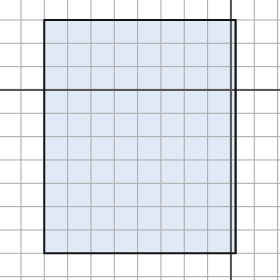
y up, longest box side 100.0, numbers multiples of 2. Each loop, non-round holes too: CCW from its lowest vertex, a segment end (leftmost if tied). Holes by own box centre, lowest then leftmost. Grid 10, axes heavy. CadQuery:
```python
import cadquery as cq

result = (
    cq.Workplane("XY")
    .moveTo(-80.0, -70.0)
    .lineTo(2.0, -70.0)
    .lineTo(2.0, 30.0)
    .lineTo(-80.0, 30.0)
    .close()
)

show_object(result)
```